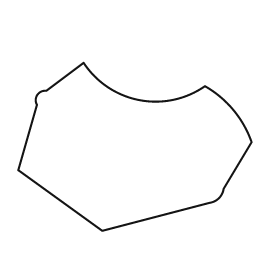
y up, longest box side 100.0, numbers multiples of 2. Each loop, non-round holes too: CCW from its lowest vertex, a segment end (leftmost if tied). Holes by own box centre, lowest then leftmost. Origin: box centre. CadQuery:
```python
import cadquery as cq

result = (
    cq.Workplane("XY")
    .moveTo(-14.0, -36.0)
    .lineTo(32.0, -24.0)
    .threePointArc((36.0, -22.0), (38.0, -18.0))
    .lineTo(50.0, 2.0)
    .threePointArc((42.0, 16.0), (30.0, 26.0))
    .threePointArc((2.0, 20.0), (-22.0, 36.0))
    .lineTo(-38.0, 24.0)
    .threePointArc((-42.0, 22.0), (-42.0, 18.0))
    .lineTo(-50.0, -10.0)
    .close()
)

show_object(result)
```